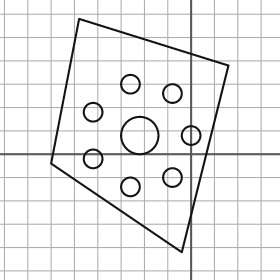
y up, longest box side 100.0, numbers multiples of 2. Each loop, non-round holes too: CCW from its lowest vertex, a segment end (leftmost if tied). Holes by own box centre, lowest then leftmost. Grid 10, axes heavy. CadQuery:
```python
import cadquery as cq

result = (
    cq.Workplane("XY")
    .moveTo(-4.0, -42.0)
    .lineTo(16.0, 38.0)
    .lineTo(-48.0, 58.0)
    .lineTo(-60.0, -4.0)
    .close()
    .moveTo(-26.0, -14.0)
    .circle(4.0)
    .moveTo(-8.0, -10.0)
    .circle(4.0)
    .moveTo(-42.0, -2.0)
    .circle(4.0)
    .moveTo(-22.0, 8.0)
    .circle(8.0)
    .moveTo(0.0, 8.0)
    .circle(4.0)
    .moveTo(-42.0, 18.0)
    .circle(4.0)
    .moveTo(-8.0, 26.0)
    .circle(4.0)
    .moveTo(-26.0, 30.0)
    .circle(4.0)
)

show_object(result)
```